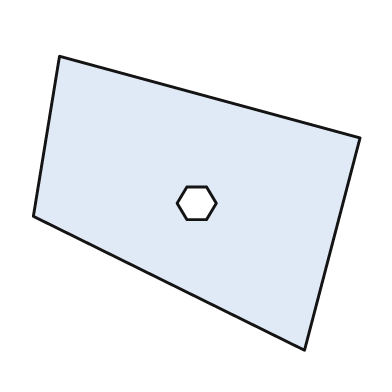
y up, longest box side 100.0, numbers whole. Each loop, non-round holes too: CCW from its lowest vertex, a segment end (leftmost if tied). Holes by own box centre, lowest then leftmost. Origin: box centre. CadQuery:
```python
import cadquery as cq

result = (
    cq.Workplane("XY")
    .moveTo(33.0, -45.0)
    .lineTo(50.0, 20.0)
    .lineTo(-42.0, 45.0)
    .lineTo(-50.0, -4.0)
    .close()
    .moveTo(-3.0, -5.0)
    .lineTo(3.0, -5.0)
    .lineTo(6.0, 0.0)
    .lineTo(3.0, 5.0)
    .lineTo(-3.0, 5.0)
    .lineTo(-6.0, 0.0)
    .close()
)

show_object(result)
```